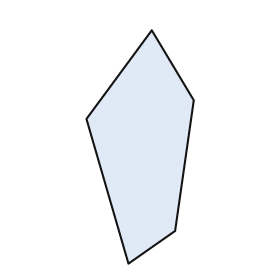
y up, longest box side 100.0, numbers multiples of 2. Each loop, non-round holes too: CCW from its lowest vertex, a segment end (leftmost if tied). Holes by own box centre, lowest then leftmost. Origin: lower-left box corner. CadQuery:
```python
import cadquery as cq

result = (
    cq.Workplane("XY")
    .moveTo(18.0, 0.0)
    .lineTo(38.0, 14.0)
    .lineTo(46.0, 70.0)
    .lineTo(28.0, 100.0)
    .lineTo(0.0, 62.0)
    .close()
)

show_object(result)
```